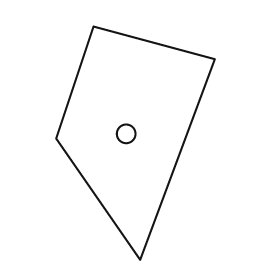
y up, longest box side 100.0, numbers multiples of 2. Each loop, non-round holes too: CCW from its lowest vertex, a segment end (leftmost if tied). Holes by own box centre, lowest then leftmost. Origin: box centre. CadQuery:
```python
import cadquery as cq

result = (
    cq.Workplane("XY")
    .moveTo(2.0, -50.0)
    .lineTo(34.0, 36.0)
    .lineTo(-18.0, 50.0)
    .lineTo(-34.0, 2.0)
    .close()
    .moveTo(-4.0, 4.0)
    .circle(4.0)
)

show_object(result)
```